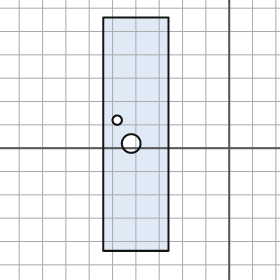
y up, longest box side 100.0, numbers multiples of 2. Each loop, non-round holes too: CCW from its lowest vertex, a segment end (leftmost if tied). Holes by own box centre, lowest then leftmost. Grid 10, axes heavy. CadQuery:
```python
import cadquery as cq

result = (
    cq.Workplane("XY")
    .moveTo(-54.0, -44.0)
    .lineTo(-26.0, -44.0)
    .lineTo(-26.0, 56.0)
    .lineTo(-54.0, 56.0)
    .close()
    .moveTo(-42.0, 2.0)
    .circle(4.0)
    .moveTo(-48.0, 12.0)
    .circle(2.0)
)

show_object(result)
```